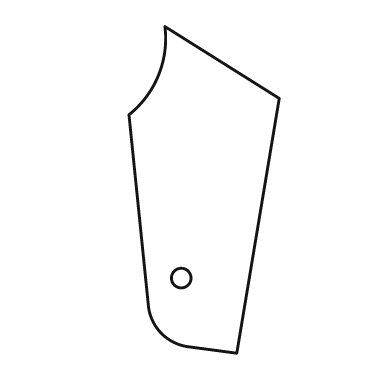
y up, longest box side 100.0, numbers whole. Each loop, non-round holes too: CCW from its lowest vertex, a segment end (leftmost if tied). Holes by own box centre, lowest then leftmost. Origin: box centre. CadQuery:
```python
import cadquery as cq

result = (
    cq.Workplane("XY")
    .moveTo(10.0, -50.0)
    .lineTo(23.0, 28.0)
    .lineTo(-12.0, 50.0)
    .threePointArc((-14.0, 35.0), (-23.0, 23.0))
    .lineTo(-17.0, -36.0)
    .threePointArc((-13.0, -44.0), (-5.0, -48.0))
    .close()
    .moveTo(-7.0, -27.0)
    .circle(3.0)
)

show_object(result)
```